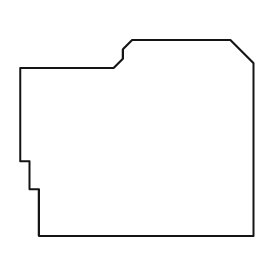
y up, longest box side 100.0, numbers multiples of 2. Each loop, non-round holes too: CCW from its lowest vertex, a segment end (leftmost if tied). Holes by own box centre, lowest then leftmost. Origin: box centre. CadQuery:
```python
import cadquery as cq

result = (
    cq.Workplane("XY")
    .moveTo(-42.0, -42.0)
    .lineTo(50.0, -42.0)
    .lineTo(50.0, 32.0)
    .lineTo(40.0, 42.0)
    .lineTo(-2.0, 42.0)
    .lineTo(-6.0, 38.0)
    .lineTo(-6.0, 34.0)
    .lineTo(-10.0, 30.0)
    .lineTo(-50.0, 30.0)
    .lineTo(-50.0, -10.0)
    .lineTo(-46.0, -10.0)
    .lineTo(-46.0, -22.0)
    .lineTo(-42.0, -22.0)
    .close()
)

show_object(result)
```